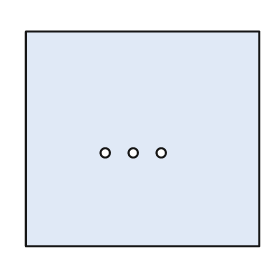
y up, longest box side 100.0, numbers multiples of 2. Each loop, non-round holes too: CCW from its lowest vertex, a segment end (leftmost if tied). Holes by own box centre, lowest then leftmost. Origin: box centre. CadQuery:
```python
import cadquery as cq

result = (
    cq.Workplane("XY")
    .moveTo(-50.0, -46.0)
    .lineTo(50.0, -46.0)
    .lineTo(50.0, 46.0)
    .lineTo(-50.0, 46.0)
    .close()
    .moveTo(-16.0, -6.0)
    .circle(2.0)
    .moveTo(-4.0, -6.0)
    .circle(2.0)
    .moveTo(8.0, -6.0)
    .circle(2.0)
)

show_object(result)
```